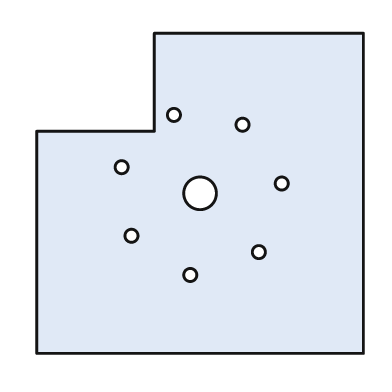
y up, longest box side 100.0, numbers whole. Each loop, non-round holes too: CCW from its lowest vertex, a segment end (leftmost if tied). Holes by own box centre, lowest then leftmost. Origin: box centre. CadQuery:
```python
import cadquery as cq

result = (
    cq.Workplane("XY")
    .moveTo(-50.0, -49.0)
    .lineTo(50.0, -49.0)
    .lineTo(50.0, 49.0)
    .lineTo(-14.0, 49.0)
    .lineTo(-14.0, 19.0)
    .lineTo(-50.0, 19.0)
    .close()
    .moveTo(-3.0, -25.0)
    .circle(2.0)
    .moveTo(18.0, -18.0)
    .circle(2.0)
    .moveTo(-21.0, -13.0)
    .circle(2.0)
    .moveTo(0.0, 0.0)
    .circle(5.0)
    .moveTo(25.0, 3.0)
    .circle(2.0)
    .moveTo(-24.0, 8.0)
    .circle(2.0)
    .moveTo(13.0, 21.0)
    .circle(2.0)
    .moveTo(-8.0, 24.0)
    .circle(2.0)
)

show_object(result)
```